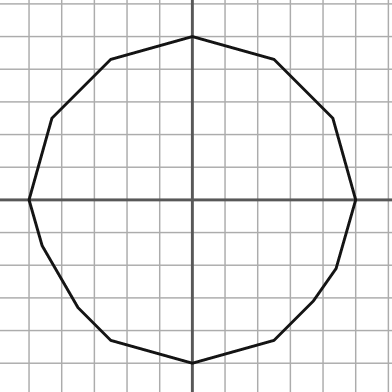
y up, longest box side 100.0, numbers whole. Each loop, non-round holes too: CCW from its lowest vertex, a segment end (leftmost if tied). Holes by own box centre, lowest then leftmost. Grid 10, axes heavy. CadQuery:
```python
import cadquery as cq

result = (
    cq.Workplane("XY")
    .moveTo(0.0, -50.0)
    .lineTo(25.0, -43.0)
    .lineTo(37.0, -31.0)
    .lineTo(44.0, -21.0)
    .lineTo(50.0, 0.0)
    .lineTo(43.0, 25.0)
    .lineTo(25.0, 43.0)
    .lineTo(0.0, 50.0)
    .lineTo(-25.0, 43.0)
    .lineTo(-43.0, 25.0)
    .lineTo(-50.0, 0.0)
    .lineTo(-46.0, -14.0)
    .lineTo(-35.0, -33.0)
    .lineTo(-25.0, -43.0)
    .close()
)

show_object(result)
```